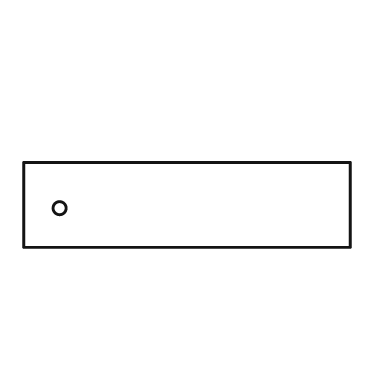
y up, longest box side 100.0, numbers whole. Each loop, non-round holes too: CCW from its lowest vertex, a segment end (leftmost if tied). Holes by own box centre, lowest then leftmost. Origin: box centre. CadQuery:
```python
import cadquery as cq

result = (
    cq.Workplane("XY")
    .moveTo(-50.0, -13.0)
    .lineTo(50.0, -13.0)
    .lineTo(50.0, 13.0)
    .lineTo(-50.0, 13.0)
    .close()
    .moveTo(-39.0, -1.0)
    .circle(2.0)
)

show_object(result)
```